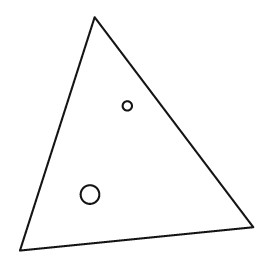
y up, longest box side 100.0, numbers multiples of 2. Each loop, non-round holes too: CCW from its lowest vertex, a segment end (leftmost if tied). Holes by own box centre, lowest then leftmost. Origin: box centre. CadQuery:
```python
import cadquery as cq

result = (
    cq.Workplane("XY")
    .moveTo(-50.0, -50.0)
    .lineTo(50.0, -40.0)
    .lineTo(-18.0, 50.0)
    .close()
    .moveTo(-20.0, -26.0)
    .circle(4.0)
    .moveTo(-4.0, 12.0)
    .circle(2.0)
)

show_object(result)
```